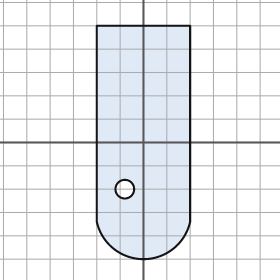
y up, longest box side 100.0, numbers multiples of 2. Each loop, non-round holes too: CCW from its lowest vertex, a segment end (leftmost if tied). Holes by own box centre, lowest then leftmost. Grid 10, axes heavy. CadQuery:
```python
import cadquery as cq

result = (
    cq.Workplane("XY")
    .moveTo(-20.0, -34.0)
    .threePointArc((0.0, -50.0), (20.0, -34.0))
    .lineTo(20.0, 50.0)
    .lineTo(-20.0, 50.0)
    .close()
    .moveTo(-8.0, -20.0)
    .circle(4.0)
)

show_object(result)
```